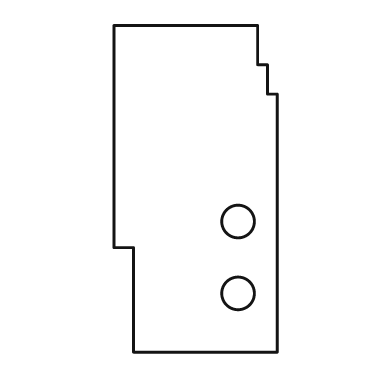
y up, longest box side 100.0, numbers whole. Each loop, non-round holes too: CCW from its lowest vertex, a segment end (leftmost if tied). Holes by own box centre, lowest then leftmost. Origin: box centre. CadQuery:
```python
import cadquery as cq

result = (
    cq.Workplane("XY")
    .moveTo(-19.0, -50.0)
    .lineTo(25.0, -50.0)
    .lineTo(25.0, 29.0)
    .lineTo(22.0, 29.0)
    .lineTo(22.0, 38.0)
    .lineTo(19.0, 38.0)
    .lineTo(19.0, 50.0)
    .lineTo(-25.0, 50.0)
    .lineTo(-25.0, -18.0)
    .lineTo(-19.0, -18.0)
    .close()
    .moveTo(13.0, -32.0)
    .circle(5.0)
    .moveTo(13.0, -10.0)
    .circle(5.0)
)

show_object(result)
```